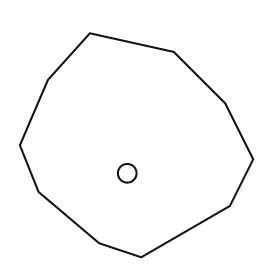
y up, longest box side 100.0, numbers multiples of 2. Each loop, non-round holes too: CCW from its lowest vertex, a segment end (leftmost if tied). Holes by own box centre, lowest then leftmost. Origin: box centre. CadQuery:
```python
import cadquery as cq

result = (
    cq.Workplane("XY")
    .moveTo(2.0, -48.0)
    .lineTo(40.0, -26.0)
    .lineTo(50.0, -6.0)
    .lineTo(38.0, 18.0)
    .lineTo(16.0, 40.0)
    .lineTo(-20.0, 48.0)
    .lineTo(-38.0, 28.0)
    .lineTo(-50.0, 0.0)
    .lineTo(-42.0, -20.0)
    .lineTo(-16.0, -42.0)
    .close()
    .moveTo(-4.0, -12.0)
    .circle(4.0)
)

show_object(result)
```